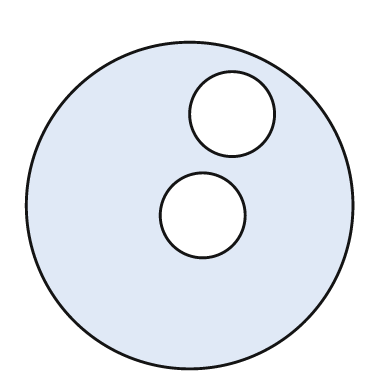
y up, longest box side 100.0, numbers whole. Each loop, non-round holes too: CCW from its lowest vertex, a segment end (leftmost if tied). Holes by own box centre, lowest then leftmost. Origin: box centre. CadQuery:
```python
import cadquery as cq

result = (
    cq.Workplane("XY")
    .moveTo(0.0, 0.0)
    .circle(50.0)
    .moveTo(4.0, -3.0)
    .circle(13.0)
    .moveTo(13.0, 28.0)
    .circle(13.0)
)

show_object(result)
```